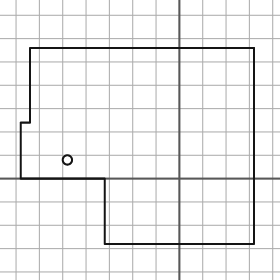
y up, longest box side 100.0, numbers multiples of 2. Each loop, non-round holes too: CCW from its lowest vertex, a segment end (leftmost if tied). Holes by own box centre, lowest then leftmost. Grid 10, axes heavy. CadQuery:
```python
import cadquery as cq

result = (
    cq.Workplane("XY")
    .moveTo(-32.0, -28.0)
    .lineTo(32.0, -28.0)
    .lineTo(32.0, 56.0)
    .lineTo(-64.0, 56.0)
    .lineTo(-64.0, 24.0)
    .lineTo(-68.0, 24.0)
    .lineTo(-68.0, 0.0)
    .lineTo(-32.0, 0.0)
    .close()
    .moveTo(-48.0, 8.0)
    .circle(2.0)
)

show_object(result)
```